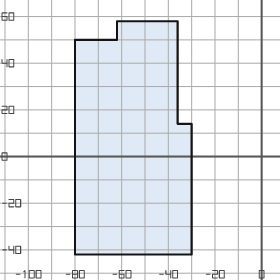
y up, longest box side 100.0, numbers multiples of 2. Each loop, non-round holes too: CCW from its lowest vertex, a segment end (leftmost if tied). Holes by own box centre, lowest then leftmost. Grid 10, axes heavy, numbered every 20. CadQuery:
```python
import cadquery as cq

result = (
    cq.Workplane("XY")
    .moveTo(-80.0, -42.0)
    .lineTo(-30.0, -42.0)
    .lineTo(-30.0, 14.0)
    .lineTo(-36.0, 14.0)
    .lineTo(-36.0, 58.0)
    .lineTo(-62.0, 58.0)
    .lineTo(-62.0, 50.0)
    .lineTo(-80.0, 50.0)
    .close()
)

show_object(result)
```